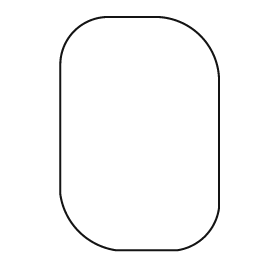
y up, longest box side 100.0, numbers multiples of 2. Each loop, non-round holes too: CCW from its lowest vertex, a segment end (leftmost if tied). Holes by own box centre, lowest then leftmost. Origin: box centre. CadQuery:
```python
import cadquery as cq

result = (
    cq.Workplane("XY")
    .moveTo(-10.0, -50.0)
    .lineTo(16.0, -50.0)
    .threePointArc((28.0, -44.0), (34.0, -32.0))
    .lineTo(34.0, 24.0)
    .threePointArc((26.0, 42.0), (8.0, 50.0))
    .lineTo(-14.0, 50.0)
    .threePointArc((-28.0, 44.0), (-34.0, 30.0))
    .lineTo(-34.0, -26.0)
    .threePointArc((-26.0, -42.0), (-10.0, -50.0))
    .close()
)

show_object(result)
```